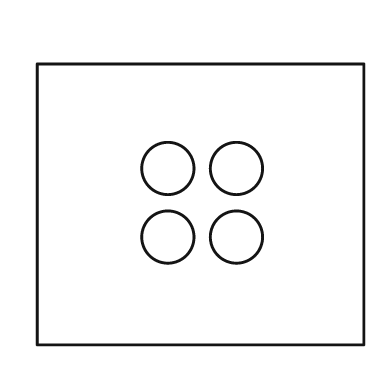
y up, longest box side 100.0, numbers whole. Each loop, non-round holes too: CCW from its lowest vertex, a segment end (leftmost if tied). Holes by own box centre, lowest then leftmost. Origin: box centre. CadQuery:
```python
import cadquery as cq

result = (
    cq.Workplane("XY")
    .moveTo(-50.0, -43.0)
    .lineTo(50.0, -43.0)
    .lineTo(50.0, 43.0)
    .lineTo(-50.0, 43.0)
    .close()
    .moveTo(-10.0, -10.0)
    .circle(8.0)
    .moveTo(11.0, -10.0)
    .circle(8.0)
    .moveTo(-10.0, 11.0)
    .circle(8.0)
    .moveTo(11.0, 11.0)
    .circle(8.0)
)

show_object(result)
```